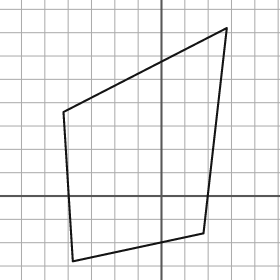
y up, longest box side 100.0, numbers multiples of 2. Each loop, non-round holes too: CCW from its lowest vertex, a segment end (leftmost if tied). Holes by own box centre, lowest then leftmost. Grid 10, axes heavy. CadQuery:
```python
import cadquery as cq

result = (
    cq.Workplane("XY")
    .moveTo(-38.0, -28.0)
    .lineTo(18.0, -16.0)
    .lineTo(28.0, 72.0)
    .lineTo(-42.0, 36.0)
    .close()
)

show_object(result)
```